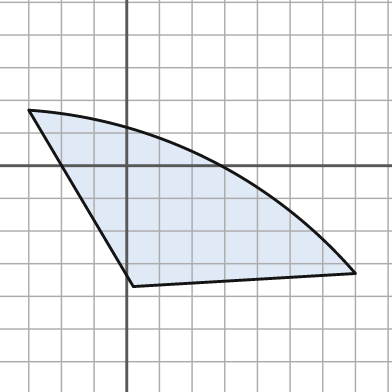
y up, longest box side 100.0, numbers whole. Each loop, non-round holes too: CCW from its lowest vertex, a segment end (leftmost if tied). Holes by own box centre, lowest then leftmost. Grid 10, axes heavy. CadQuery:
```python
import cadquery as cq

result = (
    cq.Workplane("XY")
    .moveTo(2.0, -37.0)
    .lineTo(70.0, -33.0)
    .threePointArc((25.0, 2.0), (-30.0, 17.0))
    .close()
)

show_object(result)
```